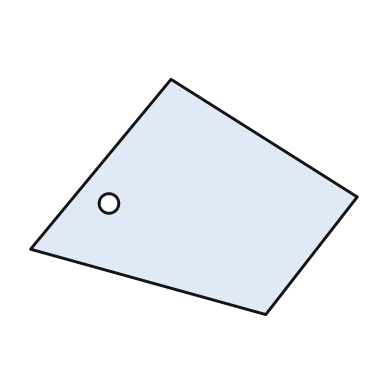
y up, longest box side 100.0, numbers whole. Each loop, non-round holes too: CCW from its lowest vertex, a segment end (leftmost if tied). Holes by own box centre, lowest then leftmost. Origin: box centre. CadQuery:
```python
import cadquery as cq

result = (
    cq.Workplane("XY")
    .moveTo(22.0, -36.0)
    .lineTo(50.0, 0.0)
    .lineTo(-7.0, 36.0)
    .lineTo(-50.0, -16.0)
    .close()
    .moveTo(-26.0, -2.0)
    .circle(3.0)
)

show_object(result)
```